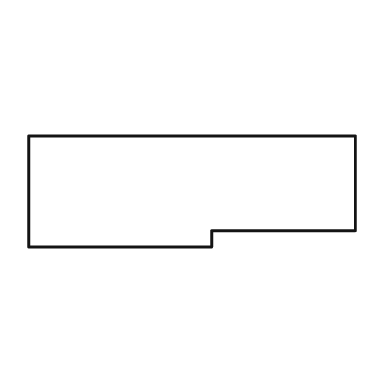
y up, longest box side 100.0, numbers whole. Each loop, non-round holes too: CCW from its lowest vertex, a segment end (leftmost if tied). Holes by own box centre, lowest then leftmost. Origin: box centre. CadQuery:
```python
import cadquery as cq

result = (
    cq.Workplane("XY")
    .moveTo(-50.0, -17.0)
    .lineTo(6.0, -17.0)
    .lineTo(6.0, -12.0)
    .lineTo(50.0, -12.0)
    .lineTo(50.0, 17.0)
    .lineTo(-50.0, 17.0)
    .close()
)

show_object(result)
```